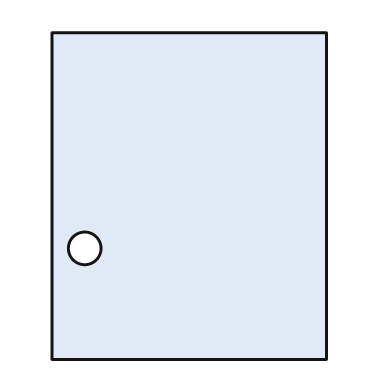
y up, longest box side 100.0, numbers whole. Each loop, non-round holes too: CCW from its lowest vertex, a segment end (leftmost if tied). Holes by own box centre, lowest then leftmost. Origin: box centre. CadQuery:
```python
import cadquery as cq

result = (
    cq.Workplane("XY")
    .moveTo(-42.0, -50.0)
    .lineTo(42.0, -50.0)
    .lineTo(42.0, 50.0)
    .lineTo(-42.0, 50.0)
    .close()
    .moveTo(-32.0, -16.0)
    .circle(5.0)
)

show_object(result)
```